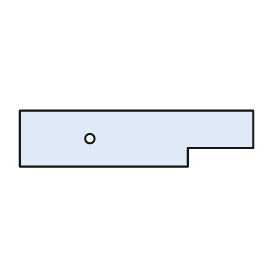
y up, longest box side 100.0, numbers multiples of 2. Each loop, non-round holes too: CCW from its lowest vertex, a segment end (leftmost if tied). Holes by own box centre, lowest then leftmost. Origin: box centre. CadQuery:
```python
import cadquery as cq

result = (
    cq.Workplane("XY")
    .moveTo(-50.0, -12.0)
    .lineTo(22.0, -12.0)
    .lineTo(22.0, -4.0)
    .lineTo(50.0, -4.0)
    .lineTo(50.0, 12.0)
    .lineTo(-50.0, 12.0)
    .close()
    .moveTo(-20.0, 0.0)
    .circle(2.0)
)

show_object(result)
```